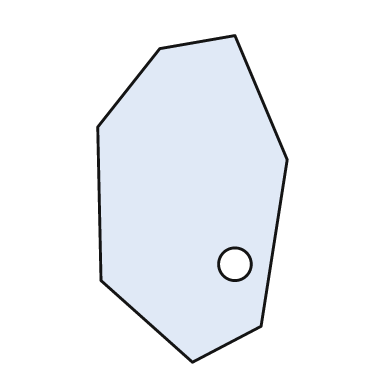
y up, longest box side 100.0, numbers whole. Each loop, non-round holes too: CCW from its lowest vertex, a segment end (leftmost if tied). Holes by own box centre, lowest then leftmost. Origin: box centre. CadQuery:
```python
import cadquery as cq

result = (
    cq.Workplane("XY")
    .moveTo(0.0, -50.0)
    .lineTo(21.0, -39.0)
    .lineTo(29.0, 12.0)
    .lineTo(13.0, 50.0)
    .lineTo(-10.0, 46.0)
    .lineTo(-29.0, 22.0)
    .lineTo(-28.0, -25.0)
    .close()
    .moveTo(13.0, -20.0)
    .circle(5.0)
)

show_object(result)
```